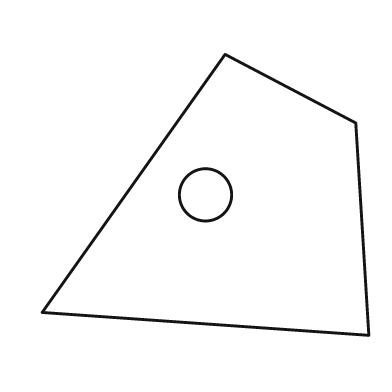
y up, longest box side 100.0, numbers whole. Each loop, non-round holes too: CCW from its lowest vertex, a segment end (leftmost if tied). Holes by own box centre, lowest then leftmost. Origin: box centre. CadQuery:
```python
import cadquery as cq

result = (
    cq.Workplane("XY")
    .moveTo(50.0, -43.0)
    .lineTo(46.0, 22.0)
    .lineTo(6.0, 43.0)
    .lineTo(-50.0, -36.0)
    .close()
    .moveTo(0.0, 0.0)
    .circle(8.0)
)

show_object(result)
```